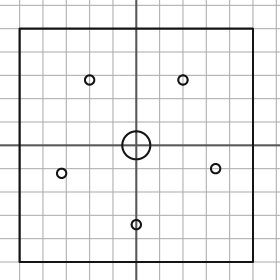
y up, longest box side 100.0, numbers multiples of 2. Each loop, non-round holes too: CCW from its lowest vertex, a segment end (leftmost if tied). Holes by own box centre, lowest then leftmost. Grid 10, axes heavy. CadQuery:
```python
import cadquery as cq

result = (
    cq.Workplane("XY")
    .moveTo(-50.0, -50.0)
    .lineTo(50.0, -50.0)
    .lineTo(50.0, 50.0)
    .lineTo(-50.0, 50.0)
    .close()
    .moveTo(0.0, -34.0)
    .circle(2.0)
    .moveTo(-32.0, -12.0)
    .circle(2.0)
    .moveTo(34.0, -10.0)
    .circle(2.0)
    .moveTo(0.0, 0.0)
    .circle(6.0)
    .moveTo(-20.0, 28.0)
    .circle(2.0)
    .moveTo(20.0, 28.0)
    .circle(2.0)
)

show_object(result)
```